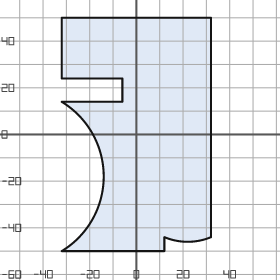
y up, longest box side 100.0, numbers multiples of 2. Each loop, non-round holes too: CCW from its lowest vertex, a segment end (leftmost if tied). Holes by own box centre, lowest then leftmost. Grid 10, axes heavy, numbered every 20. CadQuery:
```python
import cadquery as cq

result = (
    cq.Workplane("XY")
    .moveTo(-32.0, -50.0)
    .lineTo(12.0, -50.0)
    .lineTo(12.0, -44.0)
    .threePointArc((22.0, -46.0), (32.0, -44.0))
    .lineTo(32.0, 50.0)
    .lineTo(-32.0, 50.0)
    .lineTo(-32.0, 24.0)
    .lineTo(-6.0, 24.0)
    .lineTo(-6.0, 14.0)
    .lineTo(-32.0, 14.0)
    .threePointArc((-14.0, -18.0), (-32.0, -50.0))
    .close()
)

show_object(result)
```